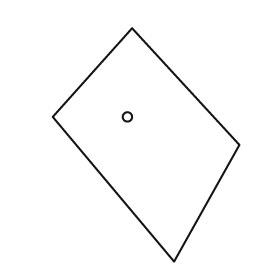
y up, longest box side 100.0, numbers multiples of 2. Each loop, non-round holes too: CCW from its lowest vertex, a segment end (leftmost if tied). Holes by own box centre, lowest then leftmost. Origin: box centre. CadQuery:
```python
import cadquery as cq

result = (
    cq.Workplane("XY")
    .moveTo(12.0, -50.0)
    .lineTo(40.0, 0.0)
    .lineTo(-6.0, 50.0)
    .lineTo(-40.0, 12.0)
    .close()
    .moveTo(-8.0, 12.0)
    .circle(2.0)
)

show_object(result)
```